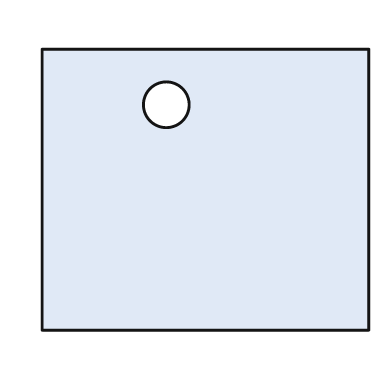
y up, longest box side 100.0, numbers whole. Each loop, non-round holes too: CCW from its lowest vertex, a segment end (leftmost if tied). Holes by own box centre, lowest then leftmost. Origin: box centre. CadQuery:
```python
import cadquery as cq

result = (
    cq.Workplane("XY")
    .moveTo(-50.0, -43.0)
    .lineTo(50.0, -43.0)
    .lineTo(50.0, 43.0)
    .lineTo(-50.0, 43.0)
    .close()
    .moveTo(-12.0, 26.0)
    .circle(7.0)
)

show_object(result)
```